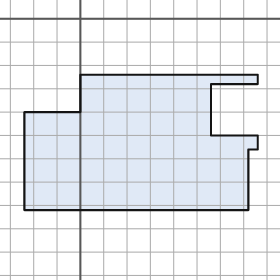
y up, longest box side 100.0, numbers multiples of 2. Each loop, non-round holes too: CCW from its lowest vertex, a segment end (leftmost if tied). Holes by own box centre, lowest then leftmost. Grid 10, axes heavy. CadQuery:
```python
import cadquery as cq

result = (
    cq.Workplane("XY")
    .moveTo(-24.0, -82.0)
    .lineTo(72.0, -82.0)
    .lineTo(72.0, -56.0)
    .lineTo(76.0, -56.0)
    .lineTo(76.0, -50.0)
    .lineTo(56.0, -50.0)
    .lineTo(56.0, -28.0)
    .lineTo(76.0, -28.0)
    .lineTo(76.0, -24.0)
    .lineTo(0.0, -24.0)
    .lineTo(0.0, -40.0)
    .lineTo(-24.0, -40.0)
    .close()
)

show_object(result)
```